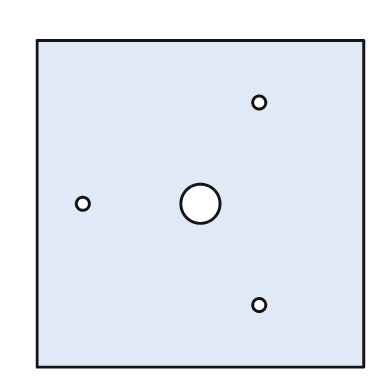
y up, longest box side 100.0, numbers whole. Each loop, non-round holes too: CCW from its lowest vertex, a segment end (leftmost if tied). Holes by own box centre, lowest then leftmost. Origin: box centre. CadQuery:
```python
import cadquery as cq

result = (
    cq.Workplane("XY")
    .moveTo(-50.0, -50.0)
    .lineTo(50.0, -50.0)
    .lineTo(50.0, 50.0)
    .lineTo(-50.0, 50.0)
    .close()
    .moveTo(18.0, -31.0)
    .circle(2.0)
    .moveTo(-36.0, 0.0)
    .circle(2.0)
    .moveTo(0.0, 0.0)
    .circle(6.0)
    .moveTo(18.0, 31.0)
    .circle(2.0)
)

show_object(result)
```